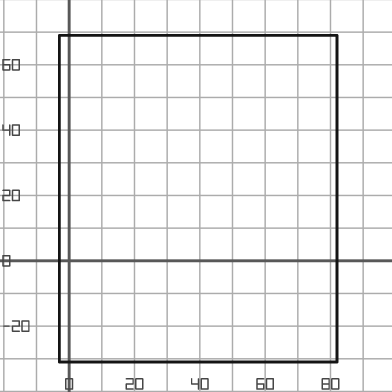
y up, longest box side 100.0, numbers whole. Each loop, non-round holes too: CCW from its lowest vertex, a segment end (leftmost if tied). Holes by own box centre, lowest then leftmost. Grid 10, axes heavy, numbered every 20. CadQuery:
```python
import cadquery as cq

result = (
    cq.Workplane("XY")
    .moveTo(-3.0, -31.0)
    .lineTo(82.0, -31.0)
    .lineTo(82.0, 69.0)
    .lineTo(-3.0, 69.0)
    .close()
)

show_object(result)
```